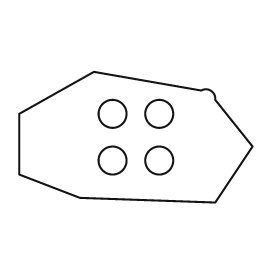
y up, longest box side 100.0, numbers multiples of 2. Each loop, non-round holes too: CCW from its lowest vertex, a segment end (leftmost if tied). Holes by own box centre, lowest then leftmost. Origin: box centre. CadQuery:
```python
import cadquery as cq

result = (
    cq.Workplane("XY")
    .moveTo(34.0, -28.0)
    .lineTo(50.0, -4.0)
    .lineTo(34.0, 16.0)
    .threePointArc((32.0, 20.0), (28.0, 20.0))
    .lineTo(-18.0, 28.0)
    .lineTo(-50.0, 10.0)
    .lineTo(-50.0, -16.0)
    .lineTo(-24.0, -26.0)
    .close()
    .moveTo(-10.0, -10.0)
    .circle(6.0)
    .moveTo(10.0, -10.0)
    .circle(6.0)
    .moveTo(-10.0, 10.0)
    .circle(6.0)
    .moveTo(10.0, 10.0)
    .circle(6.0)
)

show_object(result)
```